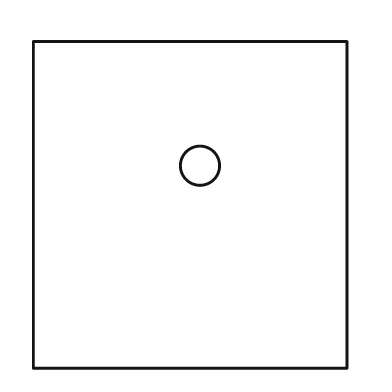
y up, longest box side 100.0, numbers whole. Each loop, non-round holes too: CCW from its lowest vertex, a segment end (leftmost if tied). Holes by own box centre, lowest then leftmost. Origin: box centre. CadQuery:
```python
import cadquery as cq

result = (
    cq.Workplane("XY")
    .moveTo(-48.0, -50.0)
    .lineTo(48.0, -50.0)
    .lineTo(48.0, 50.0)
    .lineTo(-48.0, 50.0)
    .close()
    .moveTo(3.0, 12.0)
    .circle(6.0)
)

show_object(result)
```